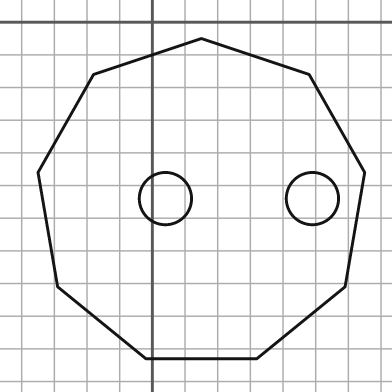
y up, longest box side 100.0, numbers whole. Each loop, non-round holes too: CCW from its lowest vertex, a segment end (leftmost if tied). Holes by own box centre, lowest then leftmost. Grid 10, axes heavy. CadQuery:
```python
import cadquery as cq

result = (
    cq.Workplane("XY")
    .moveTo(-2.0, -103.0)
    .lineTo(32.0, -103.0)
    .lineTo(59.0, -81.0)
    .lineTo(65.0, -46.0)
    .lineTo(48.0, -16.0)
    .lineTo(15.0, -5.0)
    .lineTo(-18.0, -16.0)
    .lineTo(-35.0, -46.0)
    .lineTo(-29.0, -81.0)
    .close()
    .moveTo(4.0, -54.0)
    .circle(8.0)
    .moveTo(49.0, -54.0)
    .circle(8.0)
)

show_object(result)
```